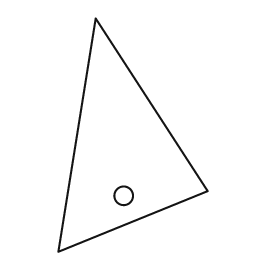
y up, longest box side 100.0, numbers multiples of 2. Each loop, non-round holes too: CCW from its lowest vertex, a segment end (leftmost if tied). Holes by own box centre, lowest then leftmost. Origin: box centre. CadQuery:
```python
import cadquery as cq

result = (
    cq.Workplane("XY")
    .moveTo(-32.0, -50.0)
    .lineTo(32.0, -24.0)
    .lineTo(-16.0, 50.0)
    .close()
    .moveTo(-4.0, -26.0)
    .circle(4.0)
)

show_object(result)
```